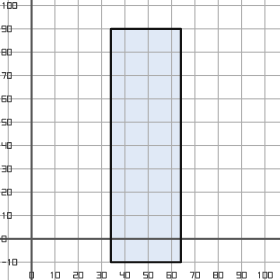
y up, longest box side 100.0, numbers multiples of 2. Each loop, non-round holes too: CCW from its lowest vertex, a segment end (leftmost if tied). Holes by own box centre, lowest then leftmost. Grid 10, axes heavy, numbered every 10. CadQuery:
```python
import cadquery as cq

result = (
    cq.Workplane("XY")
    .moveTo(34.0, -10.0)
    .lineTo(64.0, -10.0)
    .lineTo(64.0, 90.0)
    .lineTo(34.0, 90.0)
    .close()
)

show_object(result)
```